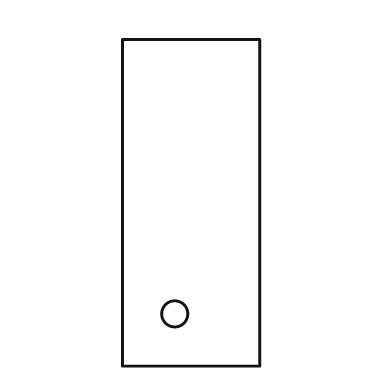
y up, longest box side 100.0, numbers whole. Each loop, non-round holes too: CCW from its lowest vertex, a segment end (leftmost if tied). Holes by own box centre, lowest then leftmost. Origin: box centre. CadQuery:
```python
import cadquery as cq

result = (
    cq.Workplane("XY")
    .moveTo(-21.0, -50.0)
    .lineTo(21.0, -50.0)
    .lineTo(21.0, 50.0)
    .lineTo(-21.0, 50.0)
    .close()
    .moveTo(-5.0, -34.0)
    .circle(4.0)
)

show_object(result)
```